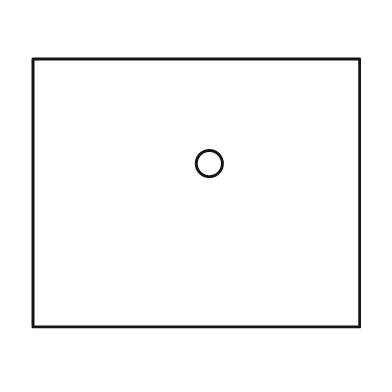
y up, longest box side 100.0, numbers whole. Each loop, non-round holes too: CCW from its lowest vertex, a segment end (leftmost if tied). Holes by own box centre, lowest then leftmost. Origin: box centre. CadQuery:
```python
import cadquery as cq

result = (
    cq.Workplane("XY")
    .moveTo(-50.0, -41.0)
    .lineTo(50.0, -41.0)
    .lineTo(50.0, 41.0)
    .lineTo(-50.0, 41.0)
    .close()
    .moveTo(4.0, 9.0)
    .circle(4.0)
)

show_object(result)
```